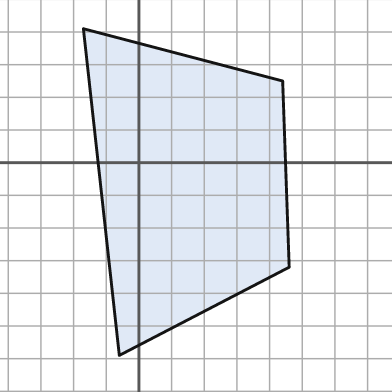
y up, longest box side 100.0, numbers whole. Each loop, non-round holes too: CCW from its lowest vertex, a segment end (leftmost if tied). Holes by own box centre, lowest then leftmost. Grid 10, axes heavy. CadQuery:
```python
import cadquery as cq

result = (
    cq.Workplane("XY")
    .moveTo(-6.0, -59.0)
    .lineTo(46.0, -32.0)
    .lineTo(44.0, 25.0)
    .lineTo(-17.0, 41.0)
    .close()
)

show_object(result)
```